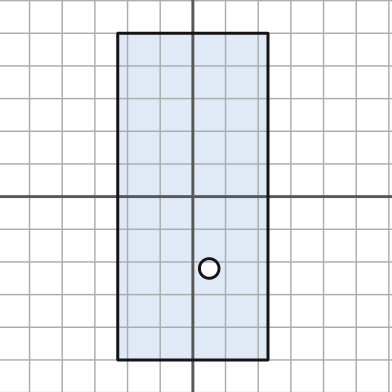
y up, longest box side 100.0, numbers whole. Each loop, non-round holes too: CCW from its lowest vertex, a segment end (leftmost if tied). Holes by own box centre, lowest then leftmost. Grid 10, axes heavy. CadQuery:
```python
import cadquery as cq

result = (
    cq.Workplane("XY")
    .moveTo(-23.0, -50.0)
    .lineTo(23.0, -50.0)
    .lineTo(23.0, 50.0)
    .lineTo(-23.0, 50.0)
    .close()
    .moveTo(5.0, -22.0)
    .circle(3.0)
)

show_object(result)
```